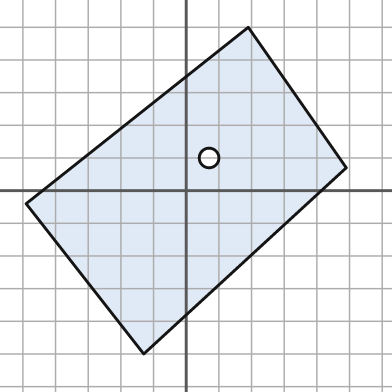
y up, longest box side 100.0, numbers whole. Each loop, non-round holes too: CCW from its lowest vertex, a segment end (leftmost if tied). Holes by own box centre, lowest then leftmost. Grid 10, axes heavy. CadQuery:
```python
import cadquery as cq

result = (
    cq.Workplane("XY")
    .moveTo(-13.0, -50.0)
    .lineTo(49.0, 7.0)
    .lineTo(19.0, 50.0)
    .lineTo(-49.0, -4.0)
    .close()
    .moveTo(7.0, 10.0)
    .circle(3.0)
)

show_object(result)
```